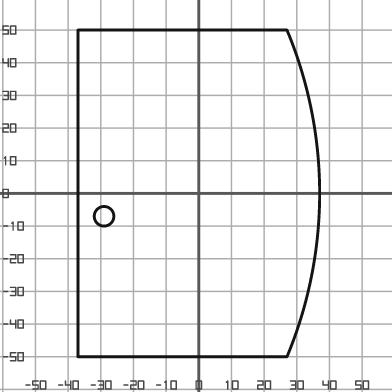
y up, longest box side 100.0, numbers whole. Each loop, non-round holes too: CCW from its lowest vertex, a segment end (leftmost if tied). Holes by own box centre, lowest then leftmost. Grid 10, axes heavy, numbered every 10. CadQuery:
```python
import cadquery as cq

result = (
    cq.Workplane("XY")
    .moveTo(-37.0, -50.0)
    .lineTo(27.0, -50.0)
    .threePointArc((37.0, 0.0), (27.0, 50.0))
    .lineTo(-37.0, 50.0)
    .close()
    .moveTo(-29.0, -7.0)
    .circle(3.0)
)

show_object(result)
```